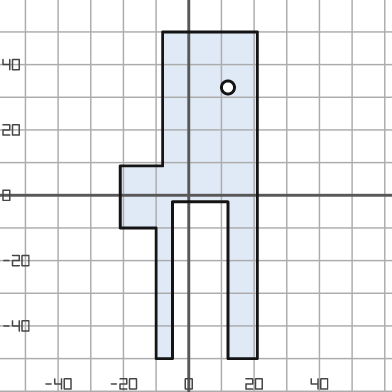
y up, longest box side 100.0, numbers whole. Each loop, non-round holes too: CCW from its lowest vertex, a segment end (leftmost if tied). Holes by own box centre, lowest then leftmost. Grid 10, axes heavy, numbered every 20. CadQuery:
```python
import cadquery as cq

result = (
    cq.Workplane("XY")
    .moveTo(-10.0, -50.0)
    .lineTo(-5.0, -50.0)
    .lineTo(-5.0, -2.0)
    .lineTo(12.0, -2.0)
    .lineTo(12.0, -50.0)
    .lineTo(21.0, -50.0)
    .lineTo(21.0, 50.0)
    .lineTo(-8.0, 50.0)
    .lineTo(-8.0, 9.0)
    .lineTo(-21.0, 9.0)
    .lineTo(-21.0, -10.0)
    .lineTo(-10.0, -10.0)
    .close()
    .moveTo(12.0, 33.0)
    .circle(2.0)
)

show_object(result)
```